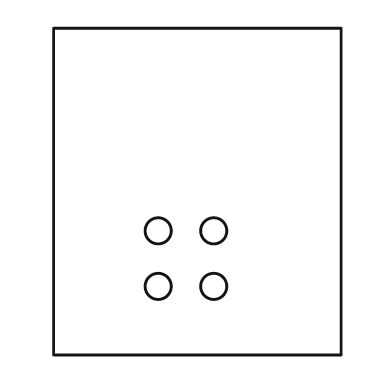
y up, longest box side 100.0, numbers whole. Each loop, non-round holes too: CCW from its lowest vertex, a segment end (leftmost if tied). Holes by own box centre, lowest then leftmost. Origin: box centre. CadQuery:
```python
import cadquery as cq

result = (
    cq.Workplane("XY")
    .moveTo(-44.0, -50.0)
    .lineTo(44.0, -50.0)
    .lineTo(44.0, 50.0)
    .lineTo(-44.0, 50.0)
    .close()
    .moveTo(-12.0, -29.0)
    .circle(4.0)
    .moveTo(5.0, -29.0)
    .circle(4.0)
    .moveTo(-12.0, -12.0)
    .circle(4.0)
    .moveTo(5.0, -12.0)
    .circle(4.0)
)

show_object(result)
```